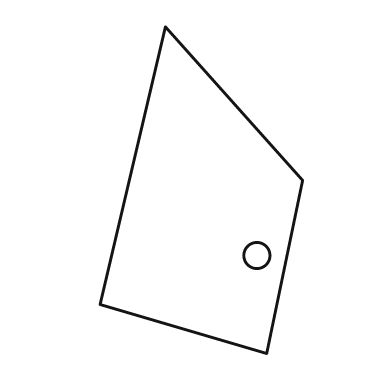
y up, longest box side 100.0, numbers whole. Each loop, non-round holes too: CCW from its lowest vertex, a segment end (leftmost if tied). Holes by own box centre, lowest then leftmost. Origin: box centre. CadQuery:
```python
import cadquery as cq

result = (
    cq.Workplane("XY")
    .moveTo(20.0, -50.0)
    .lineTo(31.0, 3.0)
    .lineTo(-11.0, 50.0)
    .lineTo(-31.0, -35.0)
    .close()
    .moveTo(17.0, -20.0)
    .circle(4.0)
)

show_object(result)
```